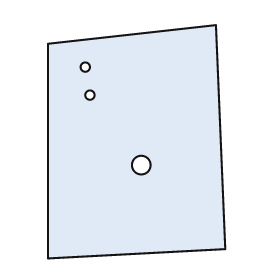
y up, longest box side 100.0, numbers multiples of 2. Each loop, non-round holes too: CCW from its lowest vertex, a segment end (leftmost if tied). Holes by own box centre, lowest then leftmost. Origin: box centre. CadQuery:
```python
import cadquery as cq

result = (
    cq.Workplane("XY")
    .moveTo(-38.0, -50.0)
    .lineTo(38.0, -46.0)
    .lineTo(34.0, 50.0)
    .lineTo(-38.0, 42.0)
    .close()
    .moveTo(2.0, -10.0)
    .circle(4.0)
    .moveTo(-20.0, 20.0)
    .circle(2.0)
    .moveTo(-22.0, 32.0)
    .circle(2.0)
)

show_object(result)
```